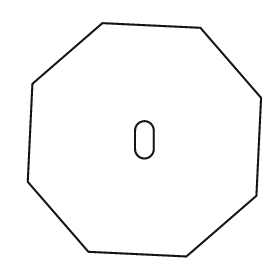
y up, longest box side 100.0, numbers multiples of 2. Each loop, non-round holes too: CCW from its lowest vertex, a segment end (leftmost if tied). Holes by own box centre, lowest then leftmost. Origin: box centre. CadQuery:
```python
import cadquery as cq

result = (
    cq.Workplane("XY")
    .moveTo(18.0, -50.0)
    .lineTo(48.0, -24.0)
    .lineTo(50.0, 18.0)
    .lineTo(24.0, 48.0)
    .lineTo(-18.0, 50.0)
    .lineTo(-48.0, 24.0)
    .lineTo(-50.0, -18.0)
    .lineTo(-24.0, -48.0)
    .close()
    .moveTo(-4.0, -4.0)
    .threePointArc((0.0, -8.0), (4.0, -4.0))
    .lineTo(4.0, 4.0)
    .threePointArc((0.0, 8.0), (-4.0, 4.0))
    .close()
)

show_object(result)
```